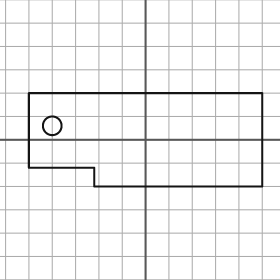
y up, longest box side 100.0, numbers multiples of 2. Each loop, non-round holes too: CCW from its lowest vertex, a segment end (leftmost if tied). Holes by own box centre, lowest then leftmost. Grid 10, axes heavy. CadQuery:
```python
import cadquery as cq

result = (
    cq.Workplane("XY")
    .moveTo(-22.0, -20.0)
    .lineTo(50.0, -20.0)
    .lineTo(50.0, 20.0)
    .lineTo(-50.0, 20.0)
    .lineTo(-50.0, -12.0)
    .lineTo(-22.0, -12.0)
    .close()
    .moveTo(-40.0, 6.0)
    .circle(4.0)
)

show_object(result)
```